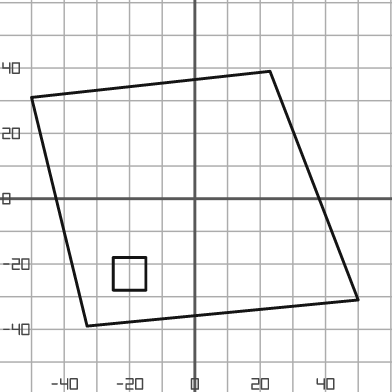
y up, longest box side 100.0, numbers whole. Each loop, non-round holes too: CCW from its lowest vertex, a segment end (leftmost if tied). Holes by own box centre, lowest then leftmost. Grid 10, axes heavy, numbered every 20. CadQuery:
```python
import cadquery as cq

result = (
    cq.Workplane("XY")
    .moveTo(-33.0, -39.0)
    .lineTo(50.0, -31.0)
    .lineTo(23.0, 39.0)
    .lineTo(-50.0, 31.0)
    .close()
    .moveTo(-25.0, -28.0)
    .lineTo(-15.0, -28.0)
    .lineTo(-15.0, -18.0)
    .lineTo(-25.0, -18.0)
    .close()
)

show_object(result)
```